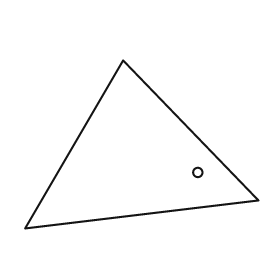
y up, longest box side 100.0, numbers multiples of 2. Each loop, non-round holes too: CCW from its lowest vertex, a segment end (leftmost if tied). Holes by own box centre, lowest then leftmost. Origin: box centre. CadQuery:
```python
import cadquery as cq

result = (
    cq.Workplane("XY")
    .moveTo(-50.0, -36.0)
    .lineTo(50.0, -24.0)
    .lineTo(-8.0, 36.0)
    .close()
    .moveTo(24.0, -12.0)
    .circle(2.0)
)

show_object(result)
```